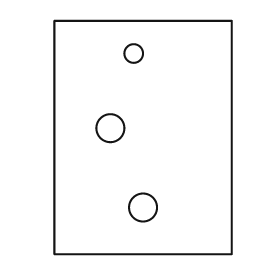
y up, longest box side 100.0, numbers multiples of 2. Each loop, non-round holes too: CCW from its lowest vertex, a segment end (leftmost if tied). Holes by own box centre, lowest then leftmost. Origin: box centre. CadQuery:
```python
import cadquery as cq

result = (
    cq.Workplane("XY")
    .moveTo(-38.0, -50.0)
    .lineTo(38.0, -50.0)
    .lineTo(38.0, 50.0)
    .lineTo(-38.0, 50.0)
    .close()
    .moveTo(0.0, -30.0)
    .circle(6.0)
    .moveTo(-14.0, 4.0)
    .circle(6.0)
    .moveTo(-4.0, 36.0)
    .circle(4.0)
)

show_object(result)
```